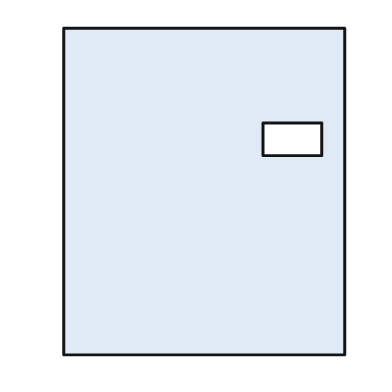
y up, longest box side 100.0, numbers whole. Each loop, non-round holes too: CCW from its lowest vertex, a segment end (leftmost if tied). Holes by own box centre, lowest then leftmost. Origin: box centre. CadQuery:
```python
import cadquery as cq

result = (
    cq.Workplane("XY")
    .moveTo(-43.0, -50.0)
    .lineTo(43.0, -50.0)
    .lineTo(43.0, 50.0)
    .lineTo(-43.0, 50.0)
    .close()
    .moveTo(18.0, 11.0)
    .lineTo(36.0, 11.0)
    .lineTo(36.0, 21.0)
    .lineTo(18.0, 21.0)
    .close()
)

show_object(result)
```